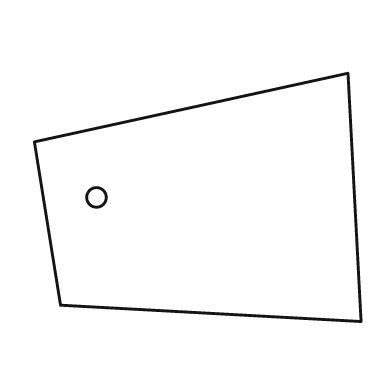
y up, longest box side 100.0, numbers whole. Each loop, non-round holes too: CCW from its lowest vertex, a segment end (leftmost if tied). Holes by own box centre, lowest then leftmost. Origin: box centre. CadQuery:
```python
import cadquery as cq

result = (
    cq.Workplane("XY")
    .moveTo(50.0, -38.0)
    .lineTo(46.0, 38.0)
    .lineTo(-50.0, 17.0)
    .lineTo(-42.0, -33.0)
    .close()
    .moveTo(-31.0, 0.0)
    .circle(3.0)
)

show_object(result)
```